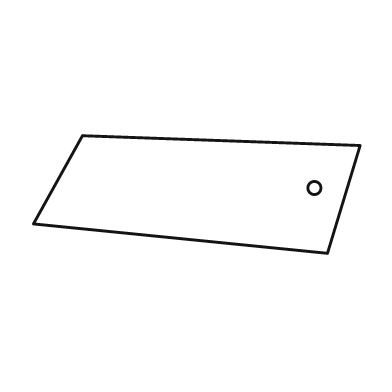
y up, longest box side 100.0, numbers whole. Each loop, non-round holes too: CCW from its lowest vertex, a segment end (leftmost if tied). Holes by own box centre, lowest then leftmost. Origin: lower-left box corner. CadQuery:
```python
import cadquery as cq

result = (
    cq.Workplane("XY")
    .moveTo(90.0, 0.0)
    .lineTo(100.0, 33.0)
    .lineTo(15.0, 36.0)
    .lineTo(0.0, 9.0)
    .close()
    .moveTo(86.0, 20.0)
    .circle(2.0)
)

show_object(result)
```